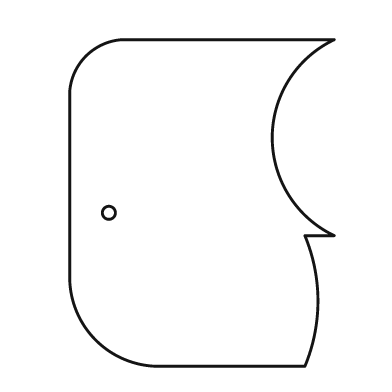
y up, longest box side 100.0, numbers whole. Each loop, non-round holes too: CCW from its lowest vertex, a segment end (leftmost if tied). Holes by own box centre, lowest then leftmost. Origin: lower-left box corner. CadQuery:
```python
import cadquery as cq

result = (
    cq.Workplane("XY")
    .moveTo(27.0, 0.0)
    .lineTo(72.0, 0.0)
    .threePointArc((76.0, 20.0), (72.0, 40.0))
    .lineTo(81.0, 40.0)
    .threePointArc((62.0, 70.0), (81.0, 100.0))
    .lineTo(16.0, 100.0)
    .threePointArc((5.0, 95.0), (0.0, 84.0))
    .lineTo(0.0, 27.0)
    .threePointArc((8.0, 8.0), (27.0, 0.0))
    .close()
    .moveTo(12.0, 47.0)
    .circle(2.0)
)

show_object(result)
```